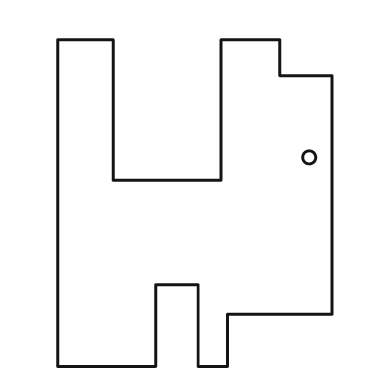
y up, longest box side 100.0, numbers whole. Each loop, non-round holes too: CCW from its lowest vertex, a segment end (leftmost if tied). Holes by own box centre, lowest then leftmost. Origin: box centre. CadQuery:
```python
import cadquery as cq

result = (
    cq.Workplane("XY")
    .moveTo(-42.0, -50.0)
    .lineTo(-12.0, -50.0)
    .lineTo(-12.0, -25.0)
    .lineTo(1.0, -25.0)
    .lineTo(1.0, -50.0)
    .lineTo(10.0, -50.0)
    .lineTo(10.0, -34.0)
    .lineTo(42.0, -34.0)
    .lineTo(42.0, 39.0)
    .lineTo(26.0, 39.0)
    .lineTo(26.0, 50.0)
    .lineTo(8.0, 50.0)
    .lineTo(8.0, 7.0)
    .lineTo(-25.0, 7.0)
    .lineTo(-25.0, 50.0)
    .lineTo(-42.0, 50.0)
    .close()
    .moveTo(35.0, 14.0)
    .circle(2.0)
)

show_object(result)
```